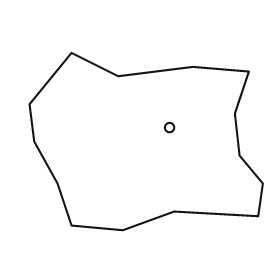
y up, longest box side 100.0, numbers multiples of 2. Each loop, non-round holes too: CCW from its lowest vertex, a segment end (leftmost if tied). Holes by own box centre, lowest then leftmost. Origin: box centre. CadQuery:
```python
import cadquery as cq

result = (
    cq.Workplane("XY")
    .moveTo(-10.0, -38.0)
    .lineTo(12.0, -30.0)
    .lineTo(48.0, -32.0)
    .lineTo(50.0, -18.0)
    .lineTo(40.0, -6.0)
    .lineTo(38.0, 12.0)
    .lineTo(44.0, 30.0)
    .lineTo(20.0, 32.0)
    .lineTo(-12.0, 28.0)
    .lineTo(-32.0, 38.0)
    .lineTo(-50.0, 16.0)
    .lineTo(-48.0, 0.0)
    .lineTo(-38.0, -18.0)
    .lineTo(-32.0, -36.0)
    .close()
    .moveTo(10.0, 6.0)
    .circle(2.0)
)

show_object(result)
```